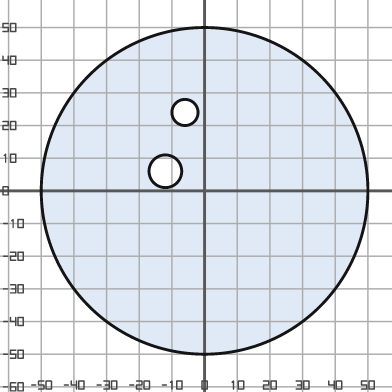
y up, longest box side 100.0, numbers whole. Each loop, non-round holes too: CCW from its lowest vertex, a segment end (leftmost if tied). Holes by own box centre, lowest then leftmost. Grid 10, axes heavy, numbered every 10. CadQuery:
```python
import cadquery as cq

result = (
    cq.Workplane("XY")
    .moveTo(0.0, 0.0)
    .circle(50.0)
    .moveTo(-12.0, 6.0)
    .circle(5.0)
    .moveTo(-6.0, 24.0)
    .circle(4.0)
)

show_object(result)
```